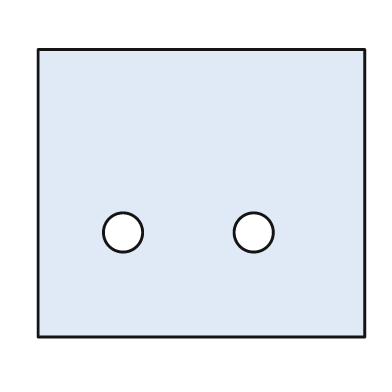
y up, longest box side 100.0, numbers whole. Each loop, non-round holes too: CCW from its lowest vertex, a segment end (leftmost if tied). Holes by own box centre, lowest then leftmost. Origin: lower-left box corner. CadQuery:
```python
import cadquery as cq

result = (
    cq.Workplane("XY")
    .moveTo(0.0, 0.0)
    .lineTo(100.0, 0.0)
    .lineTo(100.0, 88.0)
    .lineTo(0.0, 88.0)
    .close()
    .moveTo(26.0, 32.0)
    .circle(6.0)
    .moveTo(66.0, 32.0)
    .circle(6.0)
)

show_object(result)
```